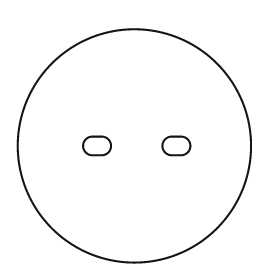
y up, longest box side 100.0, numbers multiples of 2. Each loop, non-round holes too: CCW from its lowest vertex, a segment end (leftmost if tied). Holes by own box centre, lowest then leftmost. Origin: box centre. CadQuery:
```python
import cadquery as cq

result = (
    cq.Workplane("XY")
    .moveTo(0.0, 0.0)
    .circle(50.0)
    .moveTo(-18.0, -4.0)
    .lineTo(-14.0, -4.0)
    .threePointArc((-10.0, 0.0), (-14.0, 4.0))
    .lineTo(-18.0, 4.0)
    .threePointArc((-22.0, 0.0), (-18.0, -4.0))
    .close()
    .moveTo(16.0, -4.0)
    .lineTo(20.0, -4.0)
    .threePointArc((24.0, 0.0), (20.0, 4.0))
    .lineTo(16.0, 4.0)
    .threePointArc((12.0, 0.0), (16.0, -4.0))
    .close()
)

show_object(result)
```